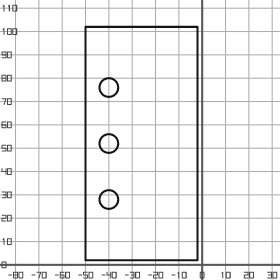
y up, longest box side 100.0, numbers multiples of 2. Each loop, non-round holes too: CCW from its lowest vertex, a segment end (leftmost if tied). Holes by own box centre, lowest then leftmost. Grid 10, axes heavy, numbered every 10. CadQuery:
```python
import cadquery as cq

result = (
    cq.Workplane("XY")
    .moveTo(-50.0, 2.0)
    .lineTo(-2.0, 2.0)
    .lineTo(-2.0, 102.0)
    .lineTo(-50.0, 102.0)
    .close()
    .moveTo(-40.0, 28.0)
    .circle(4.0)
    .moveTo(-40.0, 52.0)
    .circle(4.0)
    .moveTo(-40.0, 76.0)
    .circle(4.0)
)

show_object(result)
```